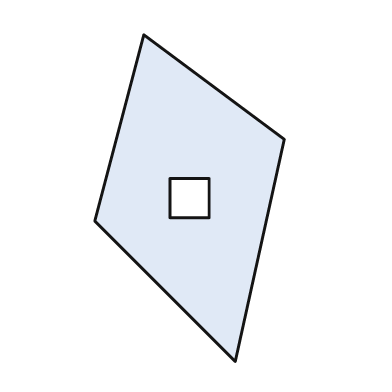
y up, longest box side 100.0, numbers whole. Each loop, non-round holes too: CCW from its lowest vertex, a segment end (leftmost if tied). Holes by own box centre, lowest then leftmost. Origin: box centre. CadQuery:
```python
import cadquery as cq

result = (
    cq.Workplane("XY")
    .moveTo(14.0, -50.0)
    .lineTo(29.0, 18.0)
    .lineTo(-14.0, 50.0)
    .lineTo(-29.0, -7.0)
    .close()
    .moveTo(-6.0, -6.0)
    .lineTo(6.0, -6.0)
    .lineTo(6.0, 6.0)
    .lineTo(-6.0, 6.0)
    .close()
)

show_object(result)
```